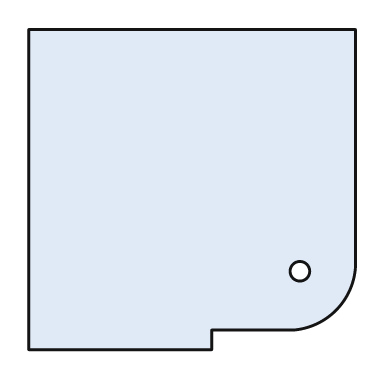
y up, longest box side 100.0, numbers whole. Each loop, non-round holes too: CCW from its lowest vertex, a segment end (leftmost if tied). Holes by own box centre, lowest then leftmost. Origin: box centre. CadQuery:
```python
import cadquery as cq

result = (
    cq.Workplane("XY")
    .moveTo(-50.0, -49.0)
    .lineTo(6.0, -49.0)
    .lineTo(6.0, -43.0)
    .lineTo(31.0, -43.0)
    .threePointArc((44.0, -37.0), (50.0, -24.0))
    .lineTo(50.0, 49.0)
    .lineTo(-50.0, 49.0)
    .close()
    .moveTo(33.0, -25.0)
    .circle(3.0)
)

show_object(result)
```